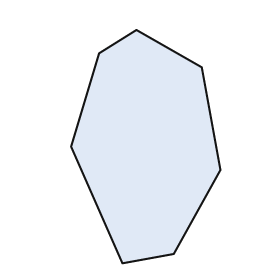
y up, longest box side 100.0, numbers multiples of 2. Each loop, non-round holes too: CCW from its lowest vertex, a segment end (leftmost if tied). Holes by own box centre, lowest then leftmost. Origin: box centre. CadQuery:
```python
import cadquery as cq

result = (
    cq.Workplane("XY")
    .moveTo(-10.0, -50.0)
    .lineTo(12.0, -46.0)
    .lineTo(32.0, -10.0)
    .lineTo(24.0, 34.0)
    .lineTo(-4.0, 50.0)
    .lineTo(-20.0, 40.0)
    .lineTo(-32.0, 0.0)
    .close()
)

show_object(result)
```